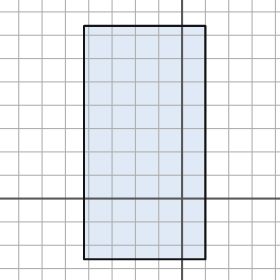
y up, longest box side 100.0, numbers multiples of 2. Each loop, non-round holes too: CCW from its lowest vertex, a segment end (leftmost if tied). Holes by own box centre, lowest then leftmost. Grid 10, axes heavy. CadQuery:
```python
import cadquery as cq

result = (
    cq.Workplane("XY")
    .moveTo(-42.0, -26.0)
    .lineTo(10.0, -26.0)
    .lineTo(10.0, 74.0)
    .lineTo(-42.0, 74.0)
    .close()
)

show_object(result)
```